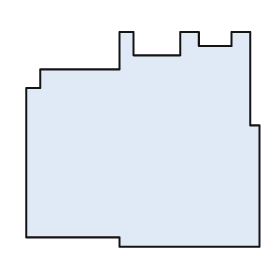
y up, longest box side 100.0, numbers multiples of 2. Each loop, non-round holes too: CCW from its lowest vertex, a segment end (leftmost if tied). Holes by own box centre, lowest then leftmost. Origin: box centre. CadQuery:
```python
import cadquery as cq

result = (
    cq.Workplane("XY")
    .moveTo(-10.0, -46.0)
    .lineTo(50.0, -46.0)
    .lineTo(50.0, 6.0)
    .lineTo(46.0, 6.0)
    .lineTo(46.0, 46.0)
    .lineTo(38.0, 46.0)
    .lineTo(38.0, 40.0)
    .lineTo(24.0, 40.0)
    .lineTo(24.0, 46.0)
    .lineTo(16.0, 46.0)
    .lineTo(16.0, 36.0)
    .lineTo(-4.0, 36.0)
    .lineTo(-4.0, 46.0)
    .lineTo(-10.0, 46.0)
    .lineTo(-10.0, 30.0)
    .lineTo(-44.0, 30.0)
    .lineTo(-44.0, 22.0)
    .lineTo(-50.0, 22.0)
    .lineTo(-50.0, -42.0)
    .lineTo(-10.0, -42.0)
    .close()
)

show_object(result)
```